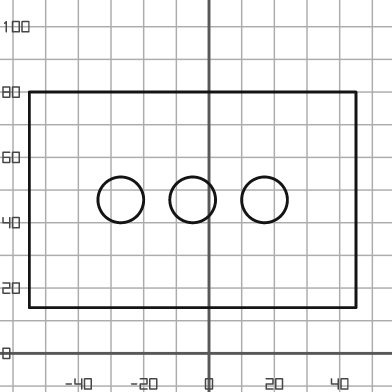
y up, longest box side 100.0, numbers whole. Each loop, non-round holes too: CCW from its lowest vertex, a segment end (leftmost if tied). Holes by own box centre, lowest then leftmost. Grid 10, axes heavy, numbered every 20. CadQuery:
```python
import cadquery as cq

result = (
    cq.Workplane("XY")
    .moveTo(-55.0, 14.0)
    .lineTo(45.0, 14.0)
    .lineTo(45.0, 80.0)
    .lineTo(-55.0, 80.0)
    .close()
    .moveTo(-27.0, 47.0)
    .circle(7.0)
    .moveTo(-5.0, 47.0)
    .circle(7.0)
    .moveTo(17.0, 47.0)
    .circle(7.0)
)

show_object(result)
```